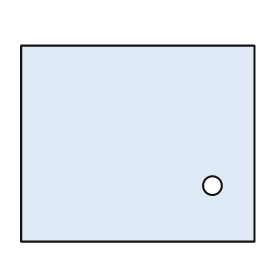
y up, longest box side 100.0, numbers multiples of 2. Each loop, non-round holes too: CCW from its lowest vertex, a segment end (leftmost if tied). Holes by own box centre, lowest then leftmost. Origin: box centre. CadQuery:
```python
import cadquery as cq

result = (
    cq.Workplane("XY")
    .moveTo(-50.0, -42.0)
    .lineTo(50.0, -42.0)
    .lineTo(50.0, 42.0)
    .lineTo(-50.0, 42.0)
    .close()
    .moveTo(32.0, -18.0)
    .circle(4.0)
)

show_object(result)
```